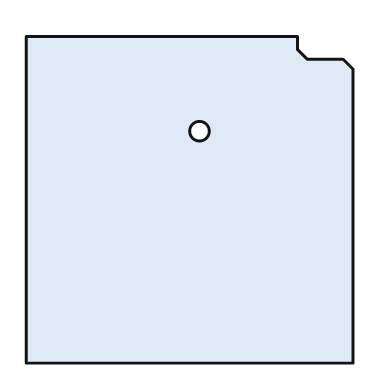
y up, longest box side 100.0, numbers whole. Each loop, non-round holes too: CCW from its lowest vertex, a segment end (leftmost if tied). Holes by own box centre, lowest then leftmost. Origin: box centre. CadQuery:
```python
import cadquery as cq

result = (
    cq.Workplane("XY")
    .moveTo(-50.0, -50.0)
    .lineTo(50.0, -50.0)
    .lineTo(50.0, 40.0)
    .lineTo(47.0, 43.0)
    .lineTo(36.0, 43.0)
    .lineTo(33.0, 46.0)
    .lineTo(33.0, 50.0)
    .lineTo(-50.0, 50.0)
    .close()
    .moveTo(3.0, 21.0)
    .circle(3.0)
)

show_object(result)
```